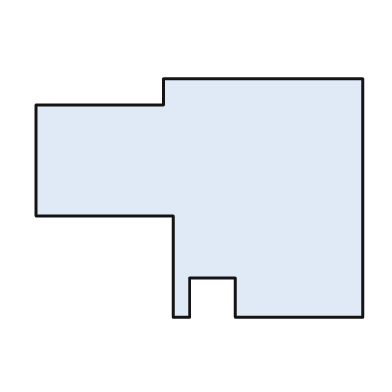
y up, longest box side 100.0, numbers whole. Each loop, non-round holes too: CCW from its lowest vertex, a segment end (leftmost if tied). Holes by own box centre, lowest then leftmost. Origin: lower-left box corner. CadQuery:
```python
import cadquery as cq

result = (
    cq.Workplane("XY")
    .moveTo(42.0, 0.0)
    .lineTo(47.0, 0.0)
    .lineTo(47.0, 12.0)
    .lineTo(61.0, 12.0)
    .lineTo(61.0, 0.0)
    .lineTo(100.0, 0.0)
    .lineTo(100.0, 73.0)
    .lineTo(39.0, 73.0)
    .lineTo(39.0, 65.0)
    .lineTo(0.0, 65.0)
    .lineTo(0.0, 31.0)
    .lineTo(42.0, 31.0)
    .close()
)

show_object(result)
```